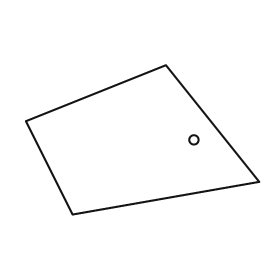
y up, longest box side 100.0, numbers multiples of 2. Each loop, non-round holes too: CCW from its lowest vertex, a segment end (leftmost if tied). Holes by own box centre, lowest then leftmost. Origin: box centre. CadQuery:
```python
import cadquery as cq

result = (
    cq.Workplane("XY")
    .moveTo(-30.0, -32.0)
    .lineTo(50.0, -18.0)
    .lineTo(10.0, 32.0)
    .lineTo(-50.0, 8.0)
    .close()
    .moveTo(22.0, 0.0)
    .circle(2.0)
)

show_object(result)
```